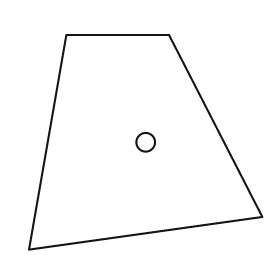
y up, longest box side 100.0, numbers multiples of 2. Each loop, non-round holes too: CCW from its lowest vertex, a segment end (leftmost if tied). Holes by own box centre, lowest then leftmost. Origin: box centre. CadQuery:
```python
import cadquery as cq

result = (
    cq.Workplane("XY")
    .moveTo(-50.0, -46.0)
    .lineTo(50.0, -32.0)
    .lineTo(10.0, 46.0)
    .lineTo(-34.0, 46.0)
    .close()
    .moveTo(0.0, 0.0)
    .circle(4.0)
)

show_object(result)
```